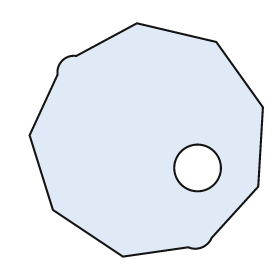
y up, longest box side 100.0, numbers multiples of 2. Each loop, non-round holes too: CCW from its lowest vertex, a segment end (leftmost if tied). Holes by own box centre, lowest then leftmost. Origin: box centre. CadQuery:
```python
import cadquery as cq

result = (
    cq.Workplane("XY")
    .moveTo(-10.0, -50.0)
    .lineTo(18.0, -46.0)
    .threePointArc((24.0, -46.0), (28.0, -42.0))
    .lineTo(48.0, -20.0)
    .lineTo(50.0, 14.0)
    .lineTo(30.0, 42.0)
    .lineTo(-4.0, 50.0)
    .lineTo(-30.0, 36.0)
    .threePointArc((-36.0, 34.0), (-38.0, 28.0))
    .lineTo(-50.0, 2.0)
    .lineTo(-40.0, -30.0)
    .close()
    .moveTo(22.0, -12.0)
    .circle(10.0)
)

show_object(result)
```